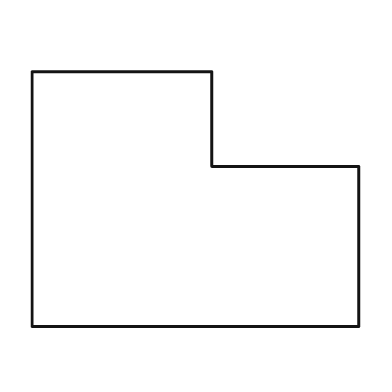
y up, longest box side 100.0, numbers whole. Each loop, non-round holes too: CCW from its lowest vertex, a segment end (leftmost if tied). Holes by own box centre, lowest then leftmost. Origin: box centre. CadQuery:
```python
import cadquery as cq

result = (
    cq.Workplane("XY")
    .moveTo(-50.0, -39.0)
    .lineTo(50.0, -39.0)
    .lineTo(50.0, 10.0)
    .lineTo(5.0, 10.0)
    .lineTo(5.0, 39.0)
    .lineTo(-50.0, 39.0)
    .close()
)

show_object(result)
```